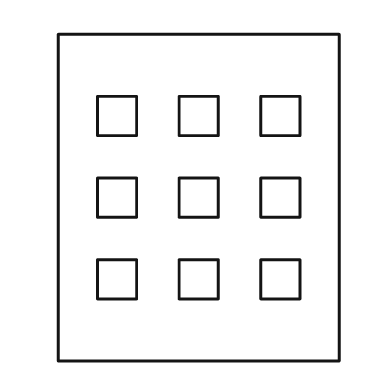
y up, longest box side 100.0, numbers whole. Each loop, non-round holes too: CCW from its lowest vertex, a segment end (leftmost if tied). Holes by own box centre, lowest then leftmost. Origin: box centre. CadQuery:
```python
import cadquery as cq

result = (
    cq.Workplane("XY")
    .moveTo(-43.0, -50.0)
    .lineTo(43.0, -50.0)
    .lineTo(43.0, 50.0)
    .lineTo(-43.0, 50.0)
    .close()
    .moveTo(-31.0, -31.0)
    .lineTo(-19.0, -31.0)
    .lineTo(-19.0, -19.0)
    .lineTo(-31.0, -19.0)
    .close()
    .moveTo(-6.0, -31.0)
    .lineTo(6.0, -31.0)
    .lineTo(6.0, -19.0)
    .lineTo(-6.0, -19.0)
    .close()
    .moveTo(19.0, -31.0)
    .lineTo(31.0, -31.0)
    .lineTo(31.0, -19.0)
    .lineTo(19.0, -19.0)
    .close()
    .moveTo(-31.0, -6.0)
    .lineTo(-19.0, -6.0)
    .lineTo(-19.0, 6.0)
    .lineTo(-31.0, 6.0)
    .close()
    .moveTo(-6.0, -6.0)
    .lineTo(6.0, -6.0)
    .lineTo(6.0, 6.0)
    .lineTo(-6.0, 6.0)
    .close()
    .moveTo(19.0, -6.0)
    .lineTo(31.0, -6.0)
    .lineTo(31.0, 6.0)
    .lineTo(19.0, 6.0)
    .close()
    .moveTo(-31.0, 19.0)
    .lineTo(-19.0, 19.0)
    .lineTo(-19.0, 31.0)
    .lineTo(-31.0, 31.0)
    .close()
    .moveTo(-6.0, 19.0)
    .lineTo(6.0, 19.0)
    .lineTo(6.0, 31.0)
    .lineTo(-6.0, 31.0)
    .close()
    .moveTo(19.0, 19.0)
    .lineTo(31.0, 19.0)
    .lineTo(31.0, 31.0)
    .lineTo(19.0, 31.0)
    .close()
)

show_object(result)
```